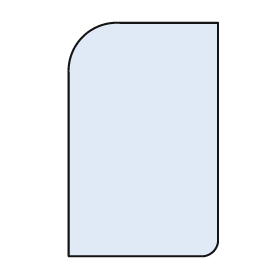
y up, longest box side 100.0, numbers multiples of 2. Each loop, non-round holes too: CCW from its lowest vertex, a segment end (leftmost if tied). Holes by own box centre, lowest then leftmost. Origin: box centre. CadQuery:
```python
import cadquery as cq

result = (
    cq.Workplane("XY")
    .moveTo(-32.0, -50.0)
    .lineTo(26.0, -50.0)
    .threePointArc((30.0, -48.0), (32.0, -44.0))
    .lineTo(32.0, 50.0)
    .lineTo(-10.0, 50.0)
    .threePointArc((-26.0, 44.0), (-32.0, 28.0))
    .close()
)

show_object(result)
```